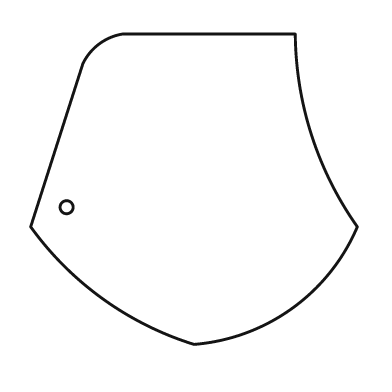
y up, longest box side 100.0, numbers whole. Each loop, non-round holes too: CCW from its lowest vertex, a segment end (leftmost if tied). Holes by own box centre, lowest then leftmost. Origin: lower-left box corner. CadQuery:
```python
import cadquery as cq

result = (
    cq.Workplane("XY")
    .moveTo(50.0, 0.0)
    .threePointArc((80.0, 11.0), (100.0, 36.0))
    .threePointArc((86.0, 64.0), (81.0, 95.0))
    .lineTo(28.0, 95.0)
    .threePointArc((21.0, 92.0), (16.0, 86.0))
    .lineTo(0.0, 36.0)
    .threePointArc((22.0, 14.0), (50.0, 0.0))
    .close()
    .moveTo(11.0, 42.0)
    .circle(2.0)
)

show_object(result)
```